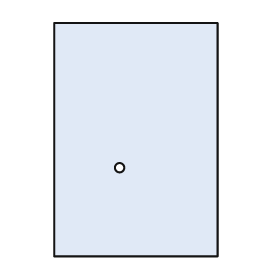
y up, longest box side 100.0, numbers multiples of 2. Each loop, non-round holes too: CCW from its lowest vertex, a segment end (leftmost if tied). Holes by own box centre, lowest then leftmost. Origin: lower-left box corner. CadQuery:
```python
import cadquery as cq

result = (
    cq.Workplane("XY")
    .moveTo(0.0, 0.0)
    .lineTo(70.0, 0.0)
    .lineTo(70.0, 100.0)
    .lineTo(0.0, 100.0)
    .close()
    .moveTo(28.0, 38.0)
    .circle(2.0)
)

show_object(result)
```